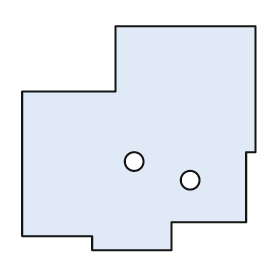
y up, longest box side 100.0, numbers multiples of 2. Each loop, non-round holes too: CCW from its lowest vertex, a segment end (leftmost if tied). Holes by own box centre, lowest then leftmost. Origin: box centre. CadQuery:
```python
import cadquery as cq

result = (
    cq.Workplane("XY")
    .moveTo(-20.0, -48.0)
    .lineTo(14.0, -48.0)
    .lineTo(14.0, -36.0)
    .lineTo(46.0, -36.0)
    .lineTo(46.0, -6.0)
    .lineTo(50.0, -6.0)
    .lineTo(50.0, 48.0)
    .lineTo(-10.0, 48.0)
    .lineTo(-10.0, 20.0)
    .lineTo(-50.0, 20.0)
    .lineTo(-50.0, -42.0)
    .lineTo(-20.0, -42.0)
    .close()
    .moveTo(22.0, -18.0)
    .circle(4.0)
    .moveTo(-2.0, -10.0)
    .circle(4.0)
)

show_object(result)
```